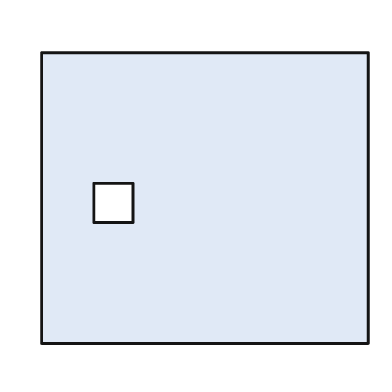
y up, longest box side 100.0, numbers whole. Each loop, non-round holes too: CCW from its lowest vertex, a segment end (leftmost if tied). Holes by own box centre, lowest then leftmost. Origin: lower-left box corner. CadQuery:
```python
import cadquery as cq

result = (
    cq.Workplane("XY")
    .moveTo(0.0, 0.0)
    .lineTo(100.0, 0.0)
    .lineTo(100.0, 89.0)
    .lineTo(0.0, 89.0)
    .close()
    .moveTo(16.0, 37.0)
    .lineTo(28.0, 37.0)
    .lineTo(28.0, 49.0)
    .lineTo(16.0, 49.0)
    .close()
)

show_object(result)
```